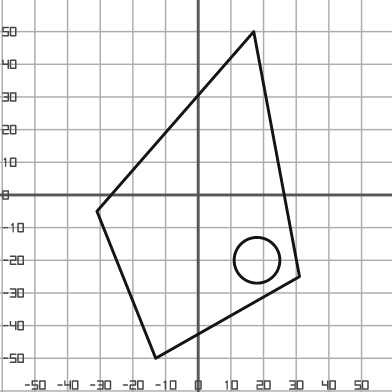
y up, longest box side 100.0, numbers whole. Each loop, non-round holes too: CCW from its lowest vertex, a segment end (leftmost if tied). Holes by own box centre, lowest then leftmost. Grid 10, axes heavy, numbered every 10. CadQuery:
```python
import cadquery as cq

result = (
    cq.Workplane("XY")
    .moveTo(-13.0, -50.0)
    .lineTo(31.0, -25.0)
    .lineTo(17.0, 50.0)
    .lineTo(-31.0, -5.0)
    .close()
    .moveTo(18.0, -20.0)
    .circle(7.0)
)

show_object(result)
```